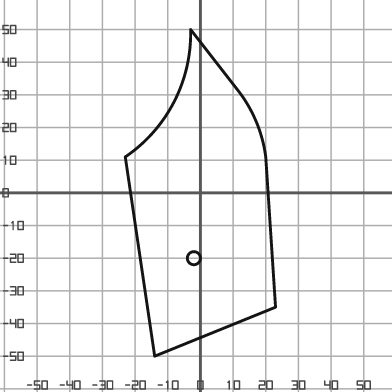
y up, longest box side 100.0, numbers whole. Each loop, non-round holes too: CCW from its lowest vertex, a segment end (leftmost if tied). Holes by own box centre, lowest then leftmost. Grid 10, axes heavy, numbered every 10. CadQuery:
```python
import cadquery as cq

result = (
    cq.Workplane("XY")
    .moveTo(-14.0, -50.0)
    .lineTo(23.0, -35.0)
    .lineTo(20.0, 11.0)
    .threePointArc((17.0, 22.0), (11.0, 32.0))
    .lineTo(-3.0, 50.0)
    .threePointArc((-8.0, 28.0), (-23.0, 11.0))
    .close()
    .moveTo(-2.0, -20.0)
    .circle(2.0)
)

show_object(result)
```